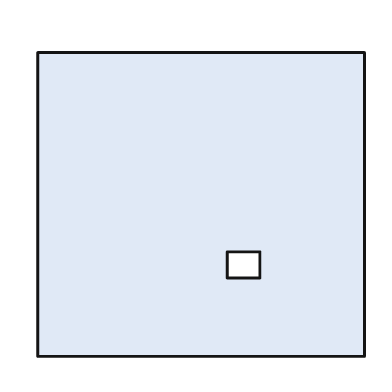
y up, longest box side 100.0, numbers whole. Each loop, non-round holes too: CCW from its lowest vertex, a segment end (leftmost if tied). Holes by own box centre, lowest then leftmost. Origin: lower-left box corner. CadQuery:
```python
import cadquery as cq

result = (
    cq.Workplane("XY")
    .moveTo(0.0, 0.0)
    .lineTo(100.0, 0.0)
    .lineTo(100.0, 93.0)
    .lineTo(0.0, 93.0)
    .close()
    .moveTo(58.0, 24.0)
    .lineTo(68.0, 24.0)
    .lineTo(68.0, 32.0)
    .lineTo(58.0, 32.0)
    .close()
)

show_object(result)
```